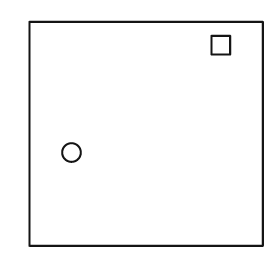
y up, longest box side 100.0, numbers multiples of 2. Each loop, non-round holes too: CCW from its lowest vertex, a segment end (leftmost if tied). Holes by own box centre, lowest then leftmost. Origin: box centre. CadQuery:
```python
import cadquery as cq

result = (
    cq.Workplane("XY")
    .moveTo(-50.0, -48.0)
    .lineTo(50.0, -48.0)
    .lineTo(50.0, 48.0)
    .lineTo(-50.0, 48.0)
    .close()
    .moveTo(-32.0, -8.0)
    .circle(4.0)
    .moveTo(28.0, 34.0)
    .lineTo(36.0, 34.0)
    .lineTo(36.0, 42.0)
    .lineTo(28.0, 42.0)
    .close()
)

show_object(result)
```